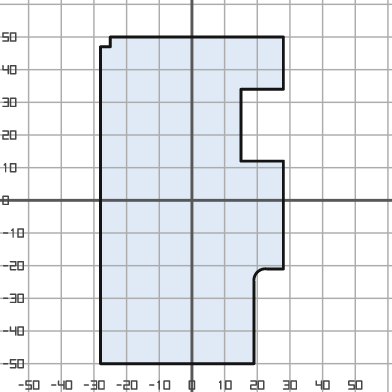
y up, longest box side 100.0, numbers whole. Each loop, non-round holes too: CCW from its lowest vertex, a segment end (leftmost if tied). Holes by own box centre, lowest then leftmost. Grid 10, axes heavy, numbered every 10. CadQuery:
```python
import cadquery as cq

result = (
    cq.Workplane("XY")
    .moveTo(-28.0, -50.0)
    .lineTo(19.0, -50.0)
    .lineTo(19.0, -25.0)
    .threePointArc((20.0, -22.0), (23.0, -21.0))
    .lineTo(28.0, -21.0)
    .lineTo(28.0, 12.0)
    .lineTo(15.0, 12.0)
    .lineTo(15.0, 34.0)
    .lineTo(28.0, 34.0)
    .lineTo(28.0, 50.0)
    .lineTo(-25.0, 50.0)
    .lineTo(-25.0, 47.0)
    .lineTo(-28.0, 47.0)
    .close()
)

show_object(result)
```